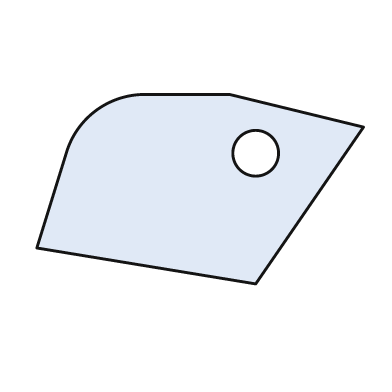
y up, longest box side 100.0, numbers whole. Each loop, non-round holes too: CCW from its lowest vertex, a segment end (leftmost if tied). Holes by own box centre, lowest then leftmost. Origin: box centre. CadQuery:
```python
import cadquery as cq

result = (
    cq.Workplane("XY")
    .moveTo(17.0, -29.0)
    .lineTo(50.0, 19.0)
    .lineTo(9.0, 29.0)
    .lineTo(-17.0, 29.0)
    .threePointArc((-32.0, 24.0), (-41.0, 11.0))
    .lineTo(-50.0, -18.0)
    .close()
    .moveTo(17.0, 11.0)
    .circle(7.0)
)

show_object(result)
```